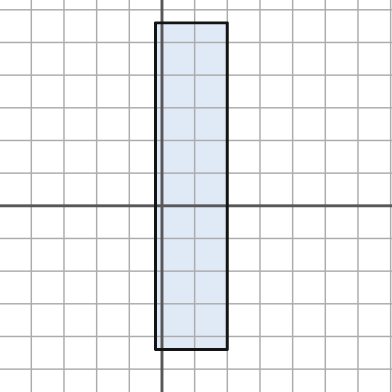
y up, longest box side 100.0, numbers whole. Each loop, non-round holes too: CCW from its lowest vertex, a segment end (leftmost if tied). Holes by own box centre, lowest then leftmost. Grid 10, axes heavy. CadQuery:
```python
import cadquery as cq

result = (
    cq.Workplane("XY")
    .moveTo(-2.0, -44.0)
    .lineTo(20.0, -44.0)
    .lineTo(20.0, 56.0)
    .lineTo(-2.0, 56.0)
    .close()
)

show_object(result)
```